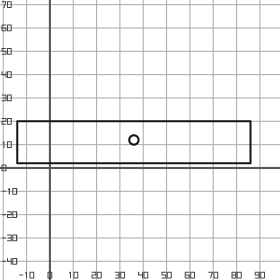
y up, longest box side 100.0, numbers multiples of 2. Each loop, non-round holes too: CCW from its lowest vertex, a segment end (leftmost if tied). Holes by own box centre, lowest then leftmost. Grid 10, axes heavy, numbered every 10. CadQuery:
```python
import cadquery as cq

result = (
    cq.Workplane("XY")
    .moveTo(-14.0, 2.0)
    .lineTo(86.0, 2.0)
    .lineTo(86.0, 20.0)
    .lineTo(-14.0, 20.0)
    .close()
    .moveTo(36.0, 12.0)
    .circle(2.0)
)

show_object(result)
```